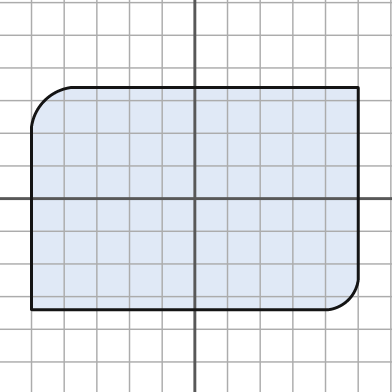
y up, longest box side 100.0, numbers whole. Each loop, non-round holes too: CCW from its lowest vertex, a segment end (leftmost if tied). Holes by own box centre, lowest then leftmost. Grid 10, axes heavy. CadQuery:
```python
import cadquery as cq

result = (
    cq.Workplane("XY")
    .moveTo(-50.0, -34.0)
    .lineTo(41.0, -34.0)
    .threePointArc((47.0, -31.0), (50.0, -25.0))
    .lineTo(50.0, 34.0)
    .lineTo(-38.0, 34.0)
    .threePointArc((-46.0, 30.0), (-50.0, 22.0))
    .close()
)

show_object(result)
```